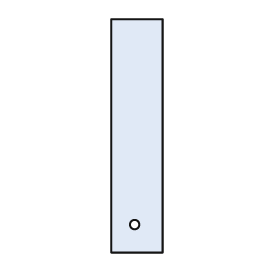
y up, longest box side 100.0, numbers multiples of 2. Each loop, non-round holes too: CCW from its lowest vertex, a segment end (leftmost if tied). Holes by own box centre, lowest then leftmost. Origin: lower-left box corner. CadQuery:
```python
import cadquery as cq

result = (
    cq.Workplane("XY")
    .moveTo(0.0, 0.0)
    .lineTo(22.0, 0.0)
    .lineTo(22.0, 100.0)
    .lineTo(0.0, 100.0)
    .close()
    .moveTo(10.0, 12.0)
    .circle(2.0)
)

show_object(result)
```